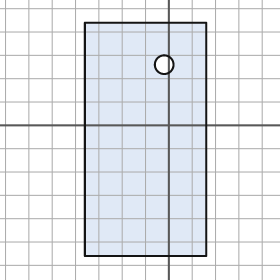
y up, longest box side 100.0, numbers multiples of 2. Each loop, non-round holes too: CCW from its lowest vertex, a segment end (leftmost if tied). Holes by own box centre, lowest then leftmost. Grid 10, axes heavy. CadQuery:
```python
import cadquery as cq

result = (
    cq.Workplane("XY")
    .moveTo(-36.0, -56.0)
    .lineTo(16.0, -56.0)
    .lineTo(16.0, 44.0)
    .lineTo(-36.0, 44.0)
    .close()
    .moveTo(-2.0, 26.0)
    .circle(4.0)
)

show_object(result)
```